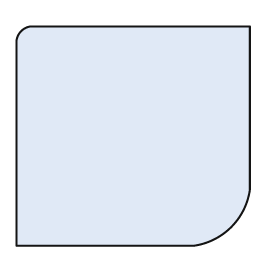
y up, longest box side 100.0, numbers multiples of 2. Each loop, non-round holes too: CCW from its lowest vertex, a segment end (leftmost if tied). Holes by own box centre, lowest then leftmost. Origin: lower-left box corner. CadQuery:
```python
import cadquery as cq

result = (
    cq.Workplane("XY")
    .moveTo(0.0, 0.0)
    .lineTo(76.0, 0.0)
    .threePointArc((92.0, 8.0), (100.0, 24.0))
    .lineTo(100.0, 94.0)
    .lineTo(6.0, 94.0)
    .threePointArc((2.0, 92.0), (0.0, 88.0))
    .close()
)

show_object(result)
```